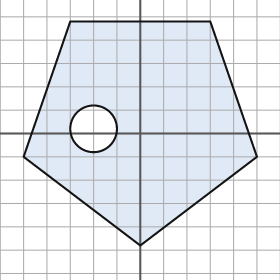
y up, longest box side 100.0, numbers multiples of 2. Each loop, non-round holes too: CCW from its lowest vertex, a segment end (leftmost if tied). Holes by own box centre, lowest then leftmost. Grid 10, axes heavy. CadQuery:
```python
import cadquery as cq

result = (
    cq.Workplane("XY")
    .moveTo(0.0, -48.0)
    .lineTo(50.0, -10.0)
    .lineTo(30.0, 48.0)
    .lineTo(-30.0, 48.0)
    .lineTo(-50.0, -10.0)
    .close()
    .moveTo(-20.0, 2.0)
    .circle(10.0)
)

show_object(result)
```